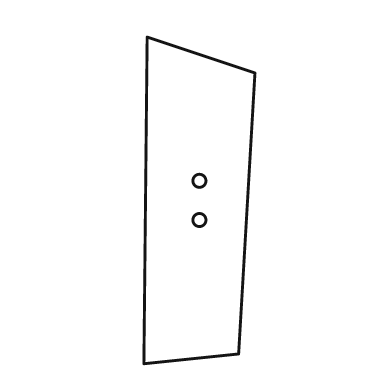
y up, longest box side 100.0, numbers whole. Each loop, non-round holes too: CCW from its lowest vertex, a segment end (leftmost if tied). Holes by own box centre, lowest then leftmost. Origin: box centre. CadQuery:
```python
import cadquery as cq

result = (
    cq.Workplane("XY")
    .moveTo(-17.0, -50.0)
    .lineTo(12.0, -47.0)
    .lineTo(17.0, 39.0)
    .lineTo(-16.0, 50.0)
    .close()
    .moveTo(0.0, -6.0)
    .circle(2.0)
    .moveTo(0.0, 6.0)
    .circle(2.0)
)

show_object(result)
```